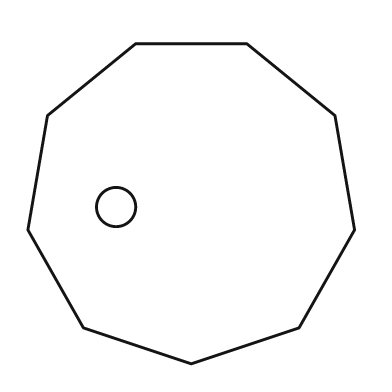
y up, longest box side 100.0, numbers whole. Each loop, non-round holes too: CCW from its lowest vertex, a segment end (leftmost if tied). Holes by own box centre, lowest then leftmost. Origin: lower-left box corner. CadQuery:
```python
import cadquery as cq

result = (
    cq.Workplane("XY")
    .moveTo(50.0, 0.0)
    .lineTo(83.0, 11.0)
    .lineTo(100.0, 41.0)
    .lineTo(94.0, 76.0)
    .lineTo(67.0, 98.0)
    .lineTo(33.0, 98.0)
    .lineTo(6.0, 76.0)
    .lineTo(0.0, 41.0)
    .lineTo(17.0, 11.0)
    .close()
    .moveTo(27.0, 48.0)
    .circle(6.0)
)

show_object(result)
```